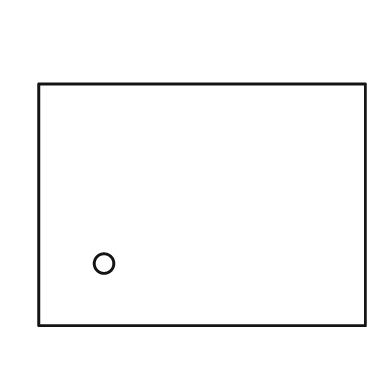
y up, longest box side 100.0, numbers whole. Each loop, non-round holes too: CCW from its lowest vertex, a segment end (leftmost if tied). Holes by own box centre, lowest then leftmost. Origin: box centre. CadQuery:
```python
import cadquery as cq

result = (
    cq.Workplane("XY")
    .moveTo(-50.0, -37.0)
    .lineTo(50.0, -37.0)
    .lineTo(50.0, 37.0)
    .lineTo(-50.0, 37.0)
    .close()
    .moveTo(-30.0, -18.0)
    .circle(3.0)
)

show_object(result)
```